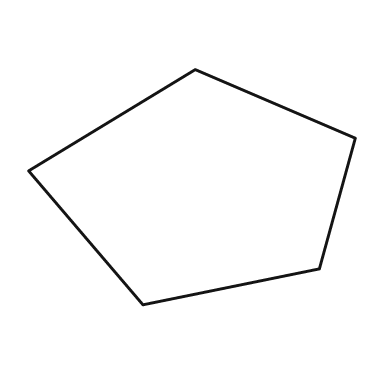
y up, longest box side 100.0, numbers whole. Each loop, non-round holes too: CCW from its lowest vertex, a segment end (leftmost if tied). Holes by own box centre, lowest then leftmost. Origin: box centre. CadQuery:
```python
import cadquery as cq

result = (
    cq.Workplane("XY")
    .moveTo(-15.0, -36.0)
    .lineTo(39.0, -25.0)
    .lineTo(50.0, 15.0)
    .lineTo(1.0, 36.0)
    .lineTo(-50.0, 5.0)
    .close()
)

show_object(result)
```